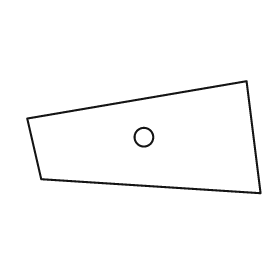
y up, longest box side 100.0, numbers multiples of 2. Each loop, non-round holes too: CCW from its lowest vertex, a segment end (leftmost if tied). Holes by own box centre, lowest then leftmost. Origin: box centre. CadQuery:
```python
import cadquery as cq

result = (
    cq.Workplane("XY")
    .moveTo(50.0, -24.0)
    .lineTo(44.0, 24.0)
    .lineTo(-50.0, 8.0)
    .lineTo(-44.0, -18.0)
    .close()
    .moveTo(0.0, 0.0)
    .circle(4.0)
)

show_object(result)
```